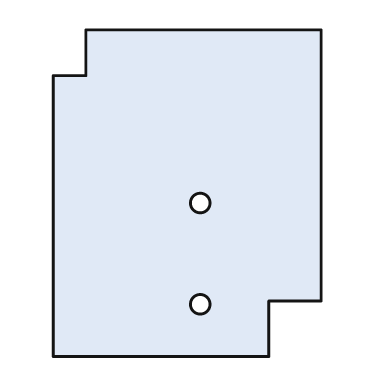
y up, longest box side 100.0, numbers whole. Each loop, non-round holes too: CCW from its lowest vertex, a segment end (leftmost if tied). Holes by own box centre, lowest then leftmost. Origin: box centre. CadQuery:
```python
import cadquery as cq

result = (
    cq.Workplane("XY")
    .moveTo(-41.0, -50.0)
    .lineTo(25.0, -50.0)
    .lineTo(25.0, -33.0)
    .lineTo(41.0, -33.0)
    .lineTo(41.0, 50.0)
    .lineTo(-31.0, 50.0)
    .lineTo(-31.0, 36.0)
    .lineTo(-41.0, 36.0)
    .close()
    .moveTo(4.0, -34.0)
    .circle(3.0)
    .moveTo(4.0, -3.0)
    .circle(3.0)
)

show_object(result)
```